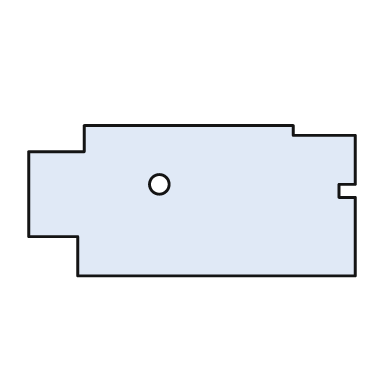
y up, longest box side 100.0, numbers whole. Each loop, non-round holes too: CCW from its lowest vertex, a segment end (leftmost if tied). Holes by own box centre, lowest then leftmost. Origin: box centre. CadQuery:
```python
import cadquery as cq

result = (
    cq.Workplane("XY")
    .moveTo(-35.0, -23.0)
    .lineTo(50.0, -23.0)
    .lineTo(50.0, 1.0)
    .lineTo(45.0, 1.0)
    .lineTo(45.0, 5.0)
    .lineTo(50.0, 5.0)
    .lineTo(50.0, 20.0)
    .lineTo(31.0, 20.0)
    .lineTo(31.0, 23.0)
    .lineTo(-33.0, 23.0)
    .lineTo(-33.0, 15.0)
    .lineTo(-50.0, 15.0)
    .lineTo(-50.0, -11.0)
    .lineTo(-35.0, -11.0)
    .close()
    .moveTo(-10.0, 5.0)
    .circle(3.0)
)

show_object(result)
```